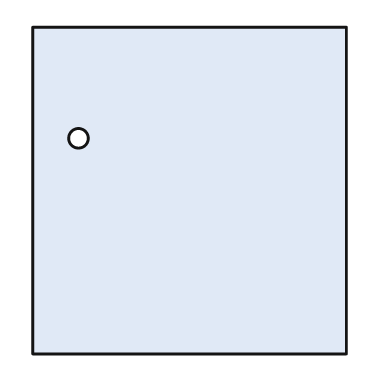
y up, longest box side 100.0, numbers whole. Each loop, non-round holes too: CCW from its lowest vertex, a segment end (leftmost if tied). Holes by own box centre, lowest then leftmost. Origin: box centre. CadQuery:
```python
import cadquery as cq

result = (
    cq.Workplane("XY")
    .moveTo(-48.0, -50.0)
    .lineTo(48.0, -50.0)
    .lineTo(48.0, 50.0)
    .lineTo(-48.0, 50.0)
    .close()
    .moveTo(-34.0, 16.0)
    .circle(3.0)
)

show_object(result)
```